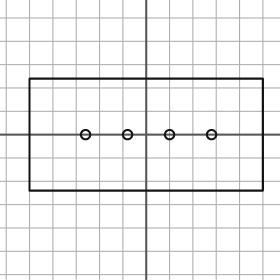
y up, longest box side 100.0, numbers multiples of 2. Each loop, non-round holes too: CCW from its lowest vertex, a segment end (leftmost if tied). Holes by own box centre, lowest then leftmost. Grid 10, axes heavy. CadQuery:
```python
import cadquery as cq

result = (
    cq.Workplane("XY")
    .moveTo(-50.0, -24.0)
    .lineTo(50.0, -24.0)
    .lineTo(50.0, 24.0)
    .lineTo(-50.0, 24.0)
    .close()
    .moveTo(-26.0, 0.0)
    .circle(2.0)
    .moveTo(-8.0, 0.0)
    .circle(2.0)
    .moveTo(10.0, 0.0)
    .circle(2.0)
    .moveTo(28.0, 0.0)
    .circle(2.0)
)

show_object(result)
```